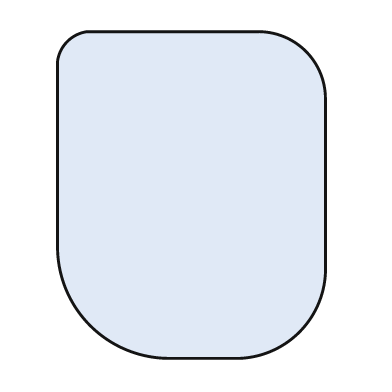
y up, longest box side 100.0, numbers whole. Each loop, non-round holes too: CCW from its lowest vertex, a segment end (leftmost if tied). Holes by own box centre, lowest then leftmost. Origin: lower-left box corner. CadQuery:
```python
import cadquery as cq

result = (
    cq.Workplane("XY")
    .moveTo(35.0, 0.0)
    .lineTo(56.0, 0.0)
    .threePointArc((74.0, 8.0), (82.0, 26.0))
    .lineTo(82.0, 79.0)
    .threePointArc((76.0, 94.0), (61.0, 100.0))
    .lineTo(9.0, 100.0)
    .threePointArc((3.0, 97.0), (0.0, 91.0))
    .lineTo(0.0, 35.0)
    .threePointArc((10.0, 10.0), (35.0, 0.0))
    .close()
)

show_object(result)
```